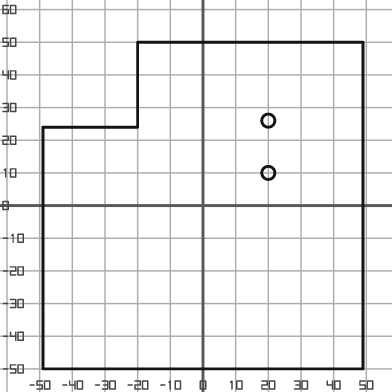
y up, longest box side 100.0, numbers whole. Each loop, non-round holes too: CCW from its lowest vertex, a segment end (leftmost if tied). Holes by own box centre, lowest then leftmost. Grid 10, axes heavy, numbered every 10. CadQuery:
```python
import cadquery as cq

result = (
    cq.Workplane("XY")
    .moveTo(-49.0, -50.0)
    .lineTo(49.0, -50.0)
    .lineTo(49.0, 50.0)
    .lineTo(-20.0, 50.0)
    .lineTo(-20.0, 24.0)
    .lineTo(-49.0, 24.0)
    .close()
    .moveTo(20.0, 10.0)
    .circle(2.0)
    .moveTo(20.0, 26.0)
    .circle(2.0)
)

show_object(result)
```